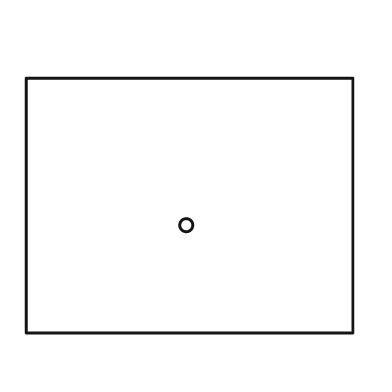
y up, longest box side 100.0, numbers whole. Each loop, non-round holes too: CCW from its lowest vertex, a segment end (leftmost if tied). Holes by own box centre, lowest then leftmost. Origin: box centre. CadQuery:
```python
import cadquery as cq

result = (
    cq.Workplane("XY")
    .moveTo(-50.0, -39.0)
    .lineTo(50.0, -39.0)
    .lineTo(50.0, 39.0)
    .lineTo(-50.0, 39.0)
    .close()
    .moveTo(-1.0, -6.0)
    .circle(2.0)
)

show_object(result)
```